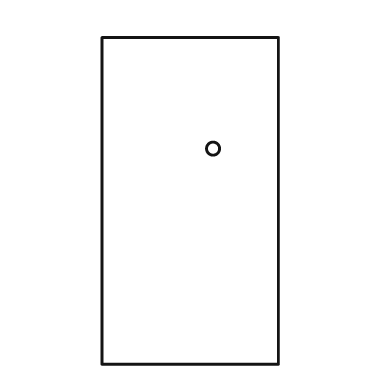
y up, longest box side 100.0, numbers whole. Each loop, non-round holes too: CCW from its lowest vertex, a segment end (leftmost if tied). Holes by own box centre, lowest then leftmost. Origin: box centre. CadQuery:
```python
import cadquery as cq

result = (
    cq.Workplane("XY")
    .moveTo(-27.0, -50.0)
    .lineTo(27.0, -50.0)
    .lineTo(27.0, 50.0)
    .lineTo(-27.0, 50.0)
    .close()
    .moveTo(7.0, 16.0)
    .circle(2.0)
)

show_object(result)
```